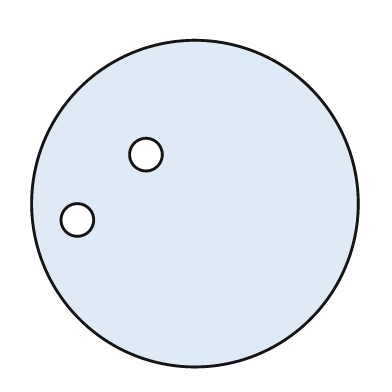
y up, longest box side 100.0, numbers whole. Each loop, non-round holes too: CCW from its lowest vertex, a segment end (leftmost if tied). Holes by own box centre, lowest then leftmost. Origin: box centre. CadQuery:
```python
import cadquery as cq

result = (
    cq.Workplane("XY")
    .moveTo(0.0, 0.0)
    .circle(50.0)
    .moveTo(-36.0, -5.0)
    .circle(5.0)
    .moveTo(-15.0, 15.0)
    .circle(5.0)
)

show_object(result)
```